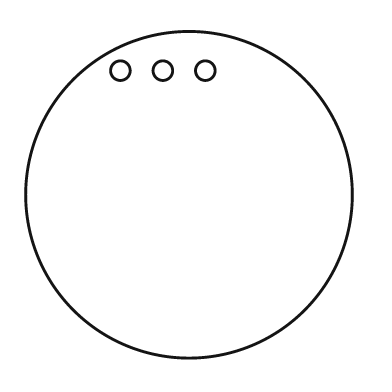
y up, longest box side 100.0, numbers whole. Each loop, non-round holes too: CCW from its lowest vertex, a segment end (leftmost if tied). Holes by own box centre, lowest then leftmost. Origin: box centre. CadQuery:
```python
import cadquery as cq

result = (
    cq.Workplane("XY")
    .moveTo(0.0, 0.0)
    .circle(50.0)
    .moveTo(-21.0, 38.0)
    .circle(3.0)
    .moveTo(-8.0, 38.0)
    .circle(3.0)
    .moveTo(5.0, 38.0)
    .circle(3.0)
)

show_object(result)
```